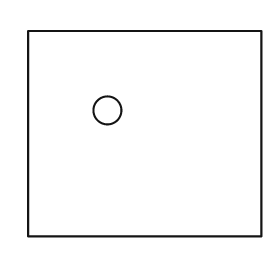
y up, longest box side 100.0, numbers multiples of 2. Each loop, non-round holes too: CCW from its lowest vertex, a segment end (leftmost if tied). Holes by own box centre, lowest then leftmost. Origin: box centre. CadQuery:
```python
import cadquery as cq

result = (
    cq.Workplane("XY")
    .moveTo(-50.0, -44.0)
    .lineTo(50.0, -44.0)
    .lineTo(50.0, 44.0)
    .lineTo(-50.0, 44.0)
    .close()
    .moveTo(-16.0, 10.0)
    .circle(6.0)
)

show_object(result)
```